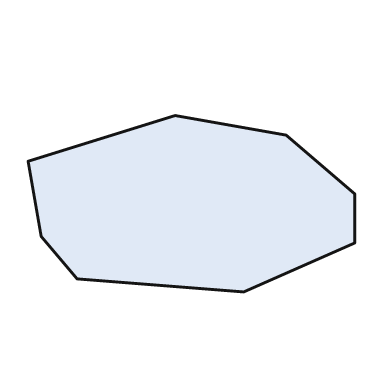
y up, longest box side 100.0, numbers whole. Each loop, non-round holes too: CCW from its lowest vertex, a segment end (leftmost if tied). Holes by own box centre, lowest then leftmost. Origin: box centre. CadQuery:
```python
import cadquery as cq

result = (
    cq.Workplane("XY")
    .moveTo(16.0, -27.0)
    .lineTo(50.0, -12.0)
    .lineTo(50.0, 3.0)
    .lineTo(29.0, 21.0)
    .lineTo(-5.0, 27.0)
    .lineTo(-50.0, 13.0)
    .lineTo(-46.0, -10.0)
    .lineTo(-35.0, -23.0)
    .close()
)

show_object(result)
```